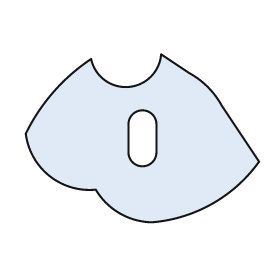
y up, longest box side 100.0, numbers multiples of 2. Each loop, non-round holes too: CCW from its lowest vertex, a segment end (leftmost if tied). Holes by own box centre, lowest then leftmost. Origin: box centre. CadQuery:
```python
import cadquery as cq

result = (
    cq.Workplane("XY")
    .moveTo(4.0, -36.0)
    .threePointArc((30.0, -28.0), (50.0, -10.0))
    .lineTo(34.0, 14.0)
    .threePointArc((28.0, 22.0), (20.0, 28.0))
    .lineTo(8.0, 36.0)
    .threePointArc((-6.0, 22.0), (-22.0, 34.0))
    .threePointArc((-38.0, 20.0), (-50.0, 2.0))
    .threePointArc((-40.0, -16.0), (-20.0, -22.0))
    .threePointArc((-10.0, -32.0), (4.0, -36.0))
    .close()
    .moveTo(-6.0, -6.0)
    .threePointArc((0.0, -12.0), (6.0, -6.0))
    .lineTo(6.0, 6.0)
    .threePointArc((0.0, 12.0), (-6.0, 6.0))
    .close()
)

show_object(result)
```